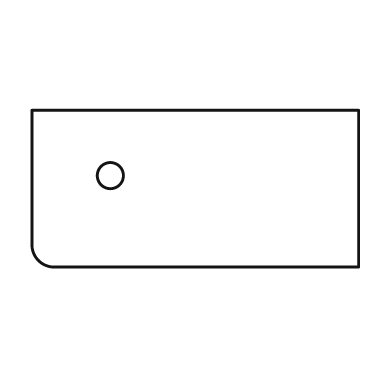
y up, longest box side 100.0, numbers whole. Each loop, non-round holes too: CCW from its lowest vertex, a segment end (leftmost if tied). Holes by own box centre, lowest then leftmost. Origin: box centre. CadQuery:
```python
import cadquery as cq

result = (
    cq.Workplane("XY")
    .moveTo(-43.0, -24.0)
    .lineTo(50.0, -24.0)
    .lineTo(50.0, 24.0)
    .lineTo(-50.0, 24.0)
    .lineTo(-50.0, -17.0)
    .threePointArc((-48.0, -22.0), (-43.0, -24.0))
    .close()
    .moveTo(-26.0, 4.0)
    .circle(4.0)
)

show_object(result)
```